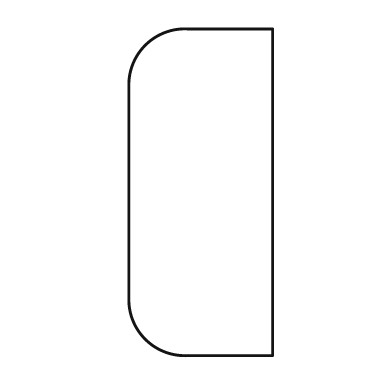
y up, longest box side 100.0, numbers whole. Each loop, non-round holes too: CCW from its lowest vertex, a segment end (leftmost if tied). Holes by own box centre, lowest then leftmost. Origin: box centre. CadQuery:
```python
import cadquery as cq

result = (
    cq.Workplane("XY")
    .moveTo(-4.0, -50.0)
    .lineTo(22.0, -50.0)
    .lineTo(22.0, 50.0)
    .lineTo(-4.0, 50.0)
    .threePointArc((-17.0, 45.0), (-22.0, 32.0))
    .lineTo(-22.0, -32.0)
    .threePointArc((-17.0, -45.0), (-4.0, -50.0))
    .close()
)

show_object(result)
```